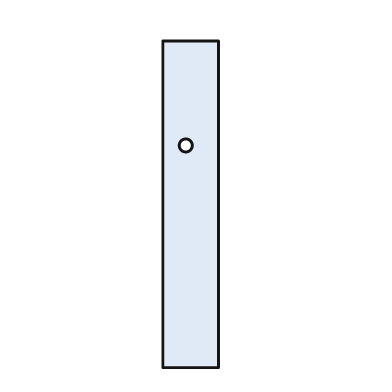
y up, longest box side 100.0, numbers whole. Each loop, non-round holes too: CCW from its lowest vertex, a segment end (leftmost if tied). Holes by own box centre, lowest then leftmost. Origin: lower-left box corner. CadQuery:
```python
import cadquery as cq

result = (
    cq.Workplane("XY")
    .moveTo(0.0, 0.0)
    .lineTo(17.0, 0.0)
    .lineTo(17.0, 100.0)
    .lineTo(0.0, 100.0)
    .close()
    .moveTo(7.0, 68.0)
    .circle(2.0)
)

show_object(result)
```